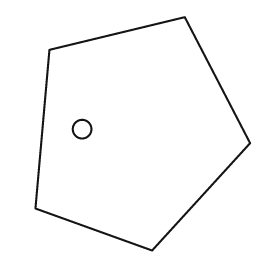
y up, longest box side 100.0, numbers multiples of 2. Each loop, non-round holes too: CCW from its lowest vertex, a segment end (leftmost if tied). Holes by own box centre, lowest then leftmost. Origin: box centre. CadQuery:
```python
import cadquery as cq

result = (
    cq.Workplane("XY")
    .moveTo(4.0, -50.0)
    .lineTo(46.0, -4.0)
    .lineTo(18.0, 50.0)
    .lineTo(-40.0, 36.0)
    .lineTo(-46.0, -32.0)
    .close()
    .moveTo(-26.0, 2.0)
    .circle(4.0)
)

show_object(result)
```